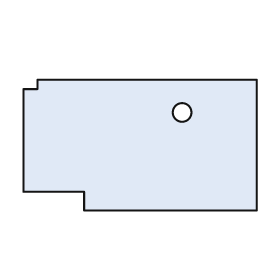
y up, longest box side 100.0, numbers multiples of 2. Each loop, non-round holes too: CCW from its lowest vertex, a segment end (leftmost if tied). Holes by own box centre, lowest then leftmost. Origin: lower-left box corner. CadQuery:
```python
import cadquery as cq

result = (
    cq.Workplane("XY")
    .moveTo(26.0, 0.0)
    .lineTo(100.0, 0.0)
    .lineTo(100.0, 56.0)
    .lineTo(6.0, 56.0)
    .lineTo(6.0, 52.0)
    .lineTo(0.0, 52.0)
    .lineTo(0.0, 8.0)
    .lineTo(26.0, 8.0)
    .close()
    .moveTo(68.0, 42.0)
    .circle(4.0)
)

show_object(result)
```